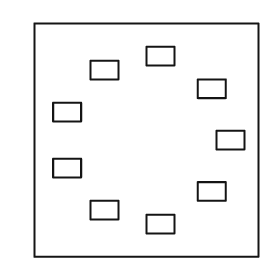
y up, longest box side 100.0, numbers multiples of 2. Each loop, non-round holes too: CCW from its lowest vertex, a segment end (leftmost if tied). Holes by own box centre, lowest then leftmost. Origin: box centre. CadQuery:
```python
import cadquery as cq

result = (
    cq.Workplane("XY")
    .moveTo(-48.0, -50.0)
    .lineTo(48.0, -50.0)
    .lineTo(48.0, 50.0)
    .lineTo(-48.0, 50.0)
    .close()
    .moveTo(0.0, -40.0)
    .lineTo(12.0, -40.0)
    .lineTo(12.0, -32.0)
    .lineTo(0.0, -32.0)
    .close()
    .moveTo(-24.0, -34.0)
    .lineTo(-12.0, -34.0)
    .lineTo(-12.0, -26.0)
    .lineTo(-24.0, -26.0)
    .close()
    .moveTo(22.0, -26.0)
    .lineTo(34.0, -26.0)
    .lineTo(34.0, -18.0)
    .lineTo(22.0, -18.0)
    .close()
    .moveTo(-40.0, -16.0)
    .lineTo(-28.0, -16.0)
    .lineTo(-28.0, -8.0)
    .lineTo(-40.0, -8.0)
    .close()
    .moveTo(30.0, -4.0)
    .lineTo(42.0, -4.0)
    .lineTo(42.0, 4.0)
    .lineTo(30.0, 4.0)
    .close()
    .moveTo(-40.0, 8.0)
    .lineTo(-28.0, 8.0)
    .lineTo(-28.0, 16.0)
    .lineTo(-40.0, 16.0)
    .close()
    .moveTo(22.0, 18.0)
    .lineTo(34.0, 18.0)
    .lineTo(34.0, 26.0)
    .lineTo(22.0, 26.0)
    .close()
    .moveTo(-24.0, 26.0)
    .lineTo(-12.0, 26.0)
    .lineTo(-12.0, 34.0)
    .lineTo(-24.0, 34.0)
    .close()
    .moveTo(0.0, 32.0)
    .lineTo(12.0, 32.0)
    .lineTo(12.0, 40.0)
    .lineTo(0.0, 40.0)
    .close()
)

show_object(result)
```